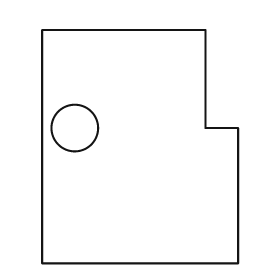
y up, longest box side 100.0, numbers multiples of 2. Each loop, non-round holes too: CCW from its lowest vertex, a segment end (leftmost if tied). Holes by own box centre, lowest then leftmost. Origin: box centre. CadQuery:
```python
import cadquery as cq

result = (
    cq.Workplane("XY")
    .moveTo(-42.0, -50.0)
    .lineTo(42.0, -50.0)
    .lineTo(42.0, 8.0)
    .lineTo(28.0, 8.0)
    .lineTo(28.0, 50.0)
    .lineTo(-42.0, 50.0)
    .close()
    .moveTo(-28.0, 8.0)
    .circle(10.0)
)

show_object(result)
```